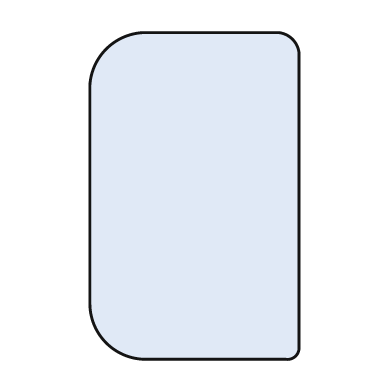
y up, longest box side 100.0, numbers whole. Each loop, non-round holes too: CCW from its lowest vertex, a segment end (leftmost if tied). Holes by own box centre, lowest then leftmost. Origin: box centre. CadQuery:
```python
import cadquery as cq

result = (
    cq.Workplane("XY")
    .moveTo(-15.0, -50.0)
    .lineTo(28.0, -50.0)
    .threePointArc((31.0, -49.0), (32.0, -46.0))
    .lineTo(32.0, 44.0)
    .threePointArc((30.0, 48.0), (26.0, 50.0))
    .lineTo(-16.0, 50.0)
    .threePointArc((-27.0, 45.0), (-32.0, 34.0))
    .lineTo(-32.0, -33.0)
    .threePointArc((-27.0, -45.0), (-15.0, -50.0))
    .close()
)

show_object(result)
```